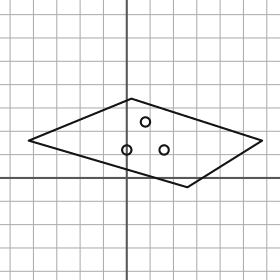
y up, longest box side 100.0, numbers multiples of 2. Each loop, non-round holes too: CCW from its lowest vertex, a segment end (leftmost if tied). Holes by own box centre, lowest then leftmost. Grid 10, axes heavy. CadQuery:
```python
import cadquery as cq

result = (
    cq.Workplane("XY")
    .moveTo(26.0, -4.0)
    .lineTo(58.0, 16.0)
    .lineTo(2.0, 34.0)
    .lineTo(-42.0, 16.0)
    .close()
    .moveTo(0.0, 12.0)
    .circle(2.0)
    .moveTo(16.0, 12.0)
    .circle(2.0)
    .moveTo(8.0, 24.0)
    .circle(2.0)
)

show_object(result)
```